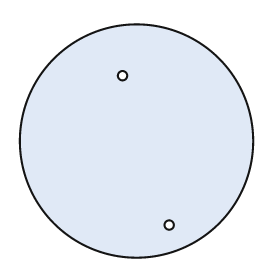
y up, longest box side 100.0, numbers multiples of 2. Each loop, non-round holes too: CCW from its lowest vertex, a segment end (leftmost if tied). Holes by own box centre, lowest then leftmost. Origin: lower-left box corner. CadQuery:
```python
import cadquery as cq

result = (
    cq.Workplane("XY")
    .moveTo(50.0, 50.0)
    .circle(50.0)
    .moveTo(64.0, 14.0)
    .circle(2.0)
    .moveTo(44.0, 78.0)
    .circle(2.0)
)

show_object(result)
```